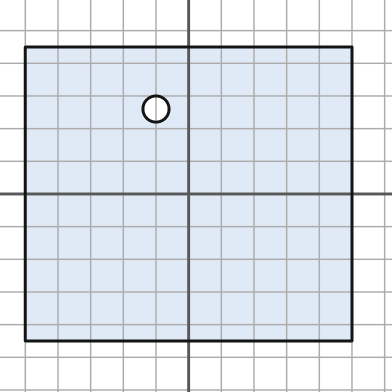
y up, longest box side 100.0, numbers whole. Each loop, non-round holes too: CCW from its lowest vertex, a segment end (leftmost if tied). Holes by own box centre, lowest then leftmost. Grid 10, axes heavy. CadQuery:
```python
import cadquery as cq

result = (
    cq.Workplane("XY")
    .moveTo(-50.0, -45.0)
    .lineTo(50.0, -45.0)
    .lineTo(50.0, 45.0)
    .lineTo(-50.0, 45.0)
    .close()
    .moveTo(-10.0, 26.0)
    .circle(4.0)
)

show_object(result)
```